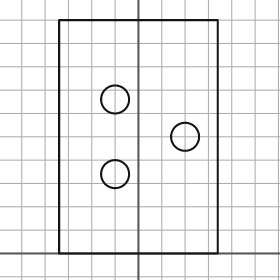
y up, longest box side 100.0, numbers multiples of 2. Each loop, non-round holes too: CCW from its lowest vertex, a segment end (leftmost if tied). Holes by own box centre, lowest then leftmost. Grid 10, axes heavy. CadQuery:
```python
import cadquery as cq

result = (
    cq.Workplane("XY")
    .moveTo(-34.0, 0.0)
    .lineTo(34.0, 0.0)
    .lineTo(34.0, 100.0)
    .lineTo(-34.0, 100.0)
    .close()
    .moveTo(-10.0, 34.0)
    .circle(6.0)
    .moveTo(20.0, 50.0)
    .circle(6.0)
    .moveTo(-10.0, 66.0)
    .circle(6.0)
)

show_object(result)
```